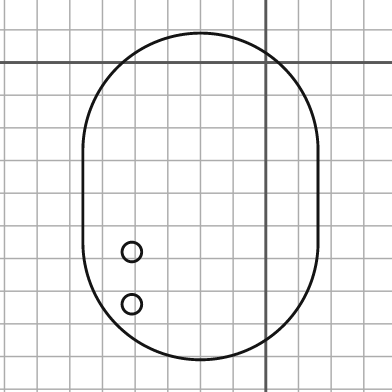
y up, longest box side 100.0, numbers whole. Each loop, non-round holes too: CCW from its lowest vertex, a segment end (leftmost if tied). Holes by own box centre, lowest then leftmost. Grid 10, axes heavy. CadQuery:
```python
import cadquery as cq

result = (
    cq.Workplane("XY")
    .moveTo(-56.0, -55.0)
    .threePointArc((-20.0, -91.0), (16.0, -55.0))
    .lineTo(16.0, -27.0)
    .threePointArc((-20.0, 9.0), (-56.0, -27.0))
    .close()
    .moveTo(-41.0, -74.0)
    .circle(3.0)
    .moveTo(-41.0, -58.0)
    .circle(3.0)
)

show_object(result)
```